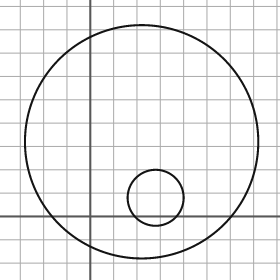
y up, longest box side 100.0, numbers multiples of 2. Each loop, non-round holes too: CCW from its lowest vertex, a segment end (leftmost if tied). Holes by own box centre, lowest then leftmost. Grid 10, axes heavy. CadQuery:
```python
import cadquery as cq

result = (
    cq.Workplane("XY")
    .moveTo(22.0, 32.0)
    .circle(50.0)
    .moveTo(28.0, 8.0)
    .circle(12.0)
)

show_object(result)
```